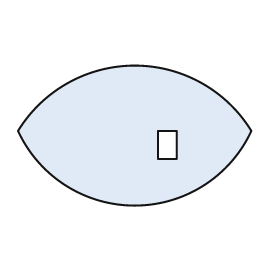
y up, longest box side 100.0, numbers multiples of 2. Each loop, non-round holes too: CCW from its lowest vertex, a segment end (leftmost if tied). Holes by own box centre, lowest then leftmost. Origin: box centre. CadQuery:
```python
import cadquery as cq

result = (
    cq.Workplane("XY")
    .moveTo(-50.0, 2.0)
    .threePointArc((0.0, -30.0), (50.0, 2.0))
    .threePointArc((0.0, 30.0), (-50.0, 2.0))
    .close()
    .moveTo(10.0, -10.0)
    .lineTo(18.0, -10.0)
    .lineTo(18.0, 2.0)
    .lineTo(10.0, 2.0)
    .close()
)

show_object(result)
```